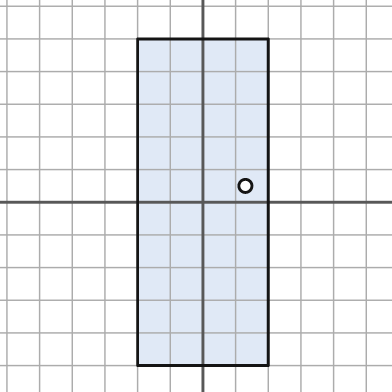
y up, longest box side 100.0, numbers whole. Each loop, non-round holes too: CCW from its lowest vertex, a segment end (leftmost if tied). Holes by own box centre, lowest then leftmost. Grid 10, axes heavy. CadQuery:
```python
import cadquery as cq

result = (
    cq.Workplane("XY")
    .moveTo(-20.0, -50.0)
    .lineTo(20.0, -50.0)
    .lineTo(20.0, 50.0)
    .lineTo(-20.0, 50.0)
    .close()
    .moveTo(13.0, 5.0)
    .circle(2.0)
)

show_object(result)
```